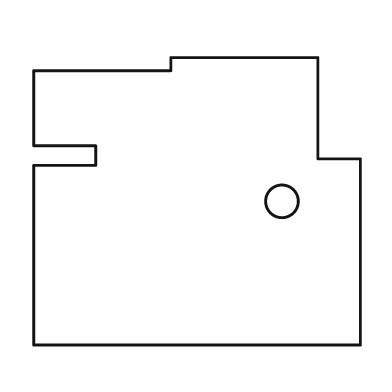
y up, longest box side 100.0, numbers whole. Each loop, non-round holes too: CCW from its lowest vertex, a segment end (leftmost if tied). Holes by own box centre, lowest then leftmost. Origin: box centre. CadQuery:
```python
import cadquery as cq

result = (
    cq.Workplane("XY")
    .moveTo(-50.0, -44.0)
    .lineTo(50.0, -44.0)
    .lineTo(50.0, 13.0)
    .lineTo(37.0, 13.0)
    .lineTo(37.0, 44.0)
    .lineTo(-8.0, 44.0)
    .lineTo(-8.0, 40.0)
    .lineTo(-50.0, 40.0)
    .lineTo(-50.0, 17.0)
    .lineTo(-31.0, 17.0)
    .lineTo(-31.0, 11.0)
    .lineTo(-50.0, 11.0)
    .close()
    .moveTo(26.0, 0.0)
    .circle(5.0)
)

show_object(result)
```